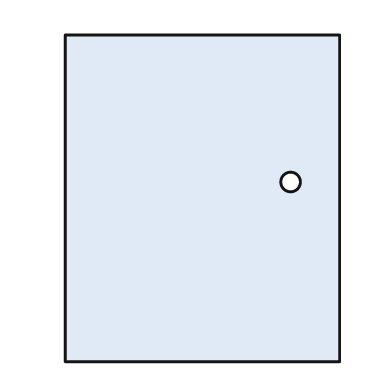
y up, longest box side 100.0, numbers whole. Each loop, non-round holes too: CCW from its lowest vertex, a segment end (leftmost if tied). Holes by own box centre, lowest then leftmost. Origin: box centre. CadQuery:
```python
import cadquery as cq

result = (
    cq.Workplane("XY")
    .moveTo(-42.0, -50.0)
    .lineTo(42.0, -50.0)
    .lineTo(42.0, 50.0)
    .lineTo(-42.0, 50.0)
    .close()
    .moveTo(27.0, 5.0)
    .circle(3.0)
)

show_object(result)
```